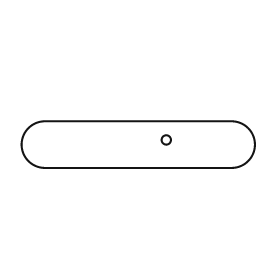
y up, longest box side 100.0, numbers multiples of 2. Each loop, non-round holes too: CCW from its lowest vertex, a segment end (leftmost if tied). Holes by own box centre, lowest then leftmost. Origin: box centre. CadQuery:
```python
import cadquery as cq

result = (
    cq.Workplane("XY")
    .moveTo(-40.0, -10.0)
    .lineTo(40.0, -10.0)
    .threePointArc((50.0, 0.0), (40.0, 10.0))
    .lineTo(-40.0, 10.0)
    .threePointArc((-50.0, 0.0), (-40.0, -10.0))
    .close()
    .moveTo(12.0, 2.0)
    .circle(2.0)
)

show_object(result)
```